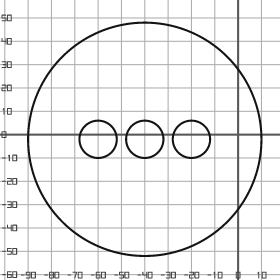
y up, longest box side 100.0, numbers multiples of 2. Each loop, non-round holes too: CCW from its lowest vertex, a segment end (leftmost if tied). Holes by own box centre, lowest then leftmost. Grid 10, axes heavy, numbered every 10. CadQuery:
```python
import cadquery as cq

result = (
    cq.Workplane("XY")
    .moveTo(-40.0, -2.0)
    .circle(50.0)
    .moveTo(-60.0, -2.0)
    .circle(8.0)
    .moveTo(-40.0, -2.0)
    .circle(8.0)
    .moveTo(-20.0, -2.0)
    .circle(8.0)
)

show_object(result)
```